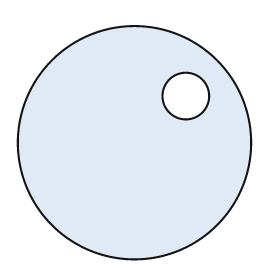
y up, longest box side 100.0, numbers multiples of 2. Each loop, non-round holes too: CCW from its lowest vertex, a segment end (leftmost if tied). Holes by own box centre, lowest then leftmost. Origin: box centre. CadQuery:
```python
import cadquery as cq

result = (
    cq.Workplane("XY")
    .moveTo(0.0, 0.0)
    .circle(50.0)
    .moveTo(22.0, 20.0)
    .circle(10.0)
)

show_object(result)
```